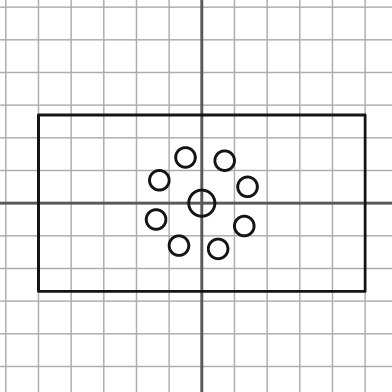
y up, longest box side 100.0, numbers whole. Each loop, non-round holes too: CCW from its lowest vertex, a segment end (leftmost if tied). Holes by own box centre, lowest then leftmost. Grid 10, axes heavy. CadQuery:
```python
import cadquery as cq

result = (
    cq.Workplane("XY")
    .moveTo(-50.0, -27.0)
    .lineTo(50.0, -27.0)
    .lineTo(50.0, 27.0)
    .lineTo(-50.0, 27.0)
    .close()
    .moveTo(5.0, -14.0)
    .circle(3.0)
    .moveTo(-7.0, -13.0)
    .circle(3.0)
    .moveTo(13.0, -7.0)
    .circle(3.0)
    .moveTo(-14.0, -5.0)
    .circle(3.0)
    .moveTo(0.0, 0.0)
    .circle(4.0)
    .moveTo(14.0, 5.0)
    .circle(3.0)
    .moveTo(-13.0, 7.0)
    .circle(3.0)
    .moveTo(7.0, 13.0)
    .circle(3.0)
    .moveTo(-5.0, 14.0)
    .circle(3.0)
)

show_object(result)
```